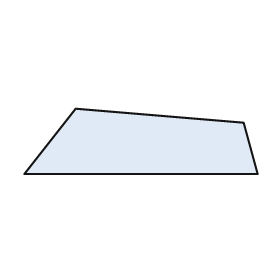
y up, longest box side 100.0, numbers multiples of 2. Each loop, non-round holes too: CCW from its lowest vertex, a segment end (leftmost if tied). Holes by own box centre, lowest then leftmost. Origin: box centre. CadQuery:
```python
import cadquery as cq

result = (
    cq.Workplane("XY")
    .moveTo(-50.0, -14.0)
    .lineTo(50.0, -14.0)
    .lineTo(44.0, 8.0)
    .lineTo(-28.0, 14.0)
    .close()
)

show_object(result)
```